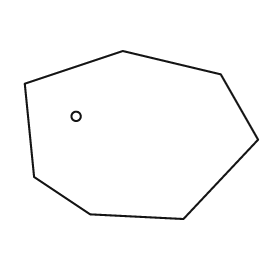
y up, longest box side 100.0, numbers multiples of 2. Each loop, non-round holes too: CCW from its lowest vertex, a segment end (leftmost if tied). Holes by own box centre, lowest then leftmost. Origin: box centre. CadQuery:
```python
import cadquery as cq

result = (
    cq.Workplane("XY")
    .moveTo(18.0, -36.0)
    .lineTo(50.0, -2.0)
    .lineTo(34.0, 26.0)
    .lineTo(-8.0, 36.0)
    .lineTo(-50.0, 22.0)
    .lineTo(-46.0, -18.0)
    .lineTo(-22.0, -34.0)
    .close()
    .moveTo(-28.0, 8.0)
    .circle(2.0)
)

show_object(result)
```